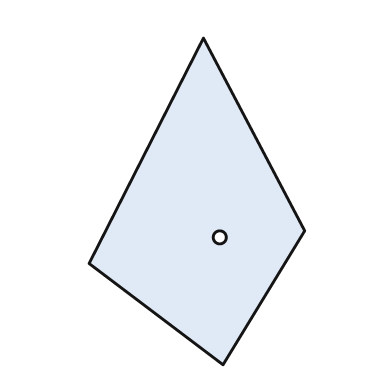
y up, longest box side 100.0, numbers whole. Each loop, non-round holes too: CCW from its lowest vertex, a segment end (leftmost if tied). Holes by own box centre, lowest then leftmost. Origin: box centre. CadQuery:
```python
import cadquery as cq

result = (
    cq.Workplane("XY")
    .moveTo(8.0, -50.0)
    .lineTo(33.0, -9.0)
    .lineTo(2.0, 50.0)
    .lineTo(-33.0, -19.0)
    .close()
    .moveTo(7.0, -11.0)
    .circle(2.0)
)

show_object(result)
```